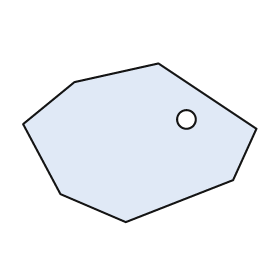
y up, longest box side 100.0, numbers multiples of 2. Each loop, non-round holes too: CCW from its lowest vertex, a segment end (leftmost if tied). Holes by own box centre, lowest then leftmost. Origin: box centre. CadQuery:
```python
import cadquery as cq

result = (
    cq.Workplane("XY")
    .moveTo(-6.0, -34.0)
    .lineTo(40.0, -16.0)
    .lineTo(50.0, 6.0)
    .lineTo(8.0, 34.0)
    .lineTo(-28.0, 26.0)
    .lineTo(-50.0, 8.0)
    .lineTo(-34.0, -22.0)
    .close()
    .moveTo(20.0, 10.0)
    .circle(4.0)
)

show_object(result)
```